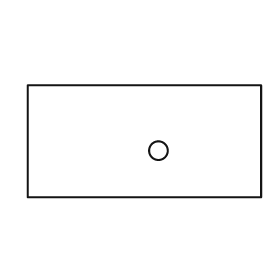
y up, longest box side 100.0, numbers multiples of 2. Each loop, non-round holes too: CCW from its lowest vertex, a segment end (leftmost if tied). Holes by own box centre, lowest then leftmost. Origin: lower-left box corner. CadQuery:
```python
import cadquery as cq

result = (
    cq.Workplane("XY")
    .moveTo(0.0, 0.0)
    .lineTo(100.0, 0.0)
    .lineTo(100.0, 48.0)
    .lineTo(0.0, 48.0)
    .close()
    .moveTo(56.0, 20.0)
    .circle(4.0)
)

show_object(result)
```